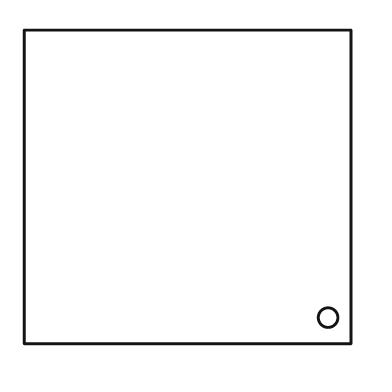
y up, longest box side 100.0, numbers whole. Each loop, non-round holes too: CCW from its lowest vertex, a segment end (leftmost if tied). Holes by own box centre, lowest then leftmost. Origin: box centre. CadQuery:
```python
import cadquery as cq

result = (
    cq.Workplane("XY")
    .moveTo(-50.0, -48.0)
    .lineTo(50.0, -48.0)
    .lineTo(50.0, 48.0)
    .lineTo(-50.0, 48.0)
    .close()
    .moveTo(43.0, -40.0)
    .circle(3.0)
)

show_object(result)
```